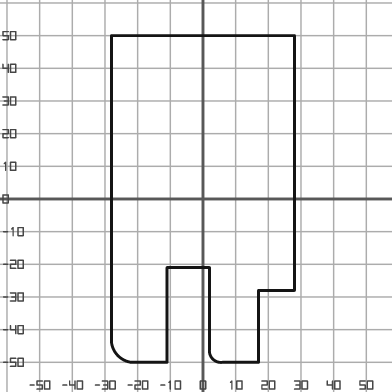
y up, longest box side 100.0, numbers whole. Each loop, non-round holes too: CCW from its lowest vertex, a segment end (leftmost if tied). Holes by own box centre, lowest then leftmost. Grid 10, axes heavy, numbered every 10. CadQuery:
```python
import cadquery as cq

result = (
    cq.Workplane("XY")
    .moveTo(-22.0, -50.0)
    .lineTo(-11.0, -50.0)
    .lineTo(-11.0, -21.0)
    .lineTo(2.0, -21.0)
    .lineTo(2.0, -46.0)
    .threePointArc((3.0, -49.0), (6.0, -50.0))
    .lineTo(17.0, -50.0)
    .lineTo(17.0, -28.0)
    .lineTo(28.0, -28.0)
    .lineTo(28.0, 50.0)
    .lineTo(-28.0, 50.0)
    .lineTo(-28.0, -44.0)
    .threePointArc((-26.0, -48.0), (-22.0, -50.0))
    .close()
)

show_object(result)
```